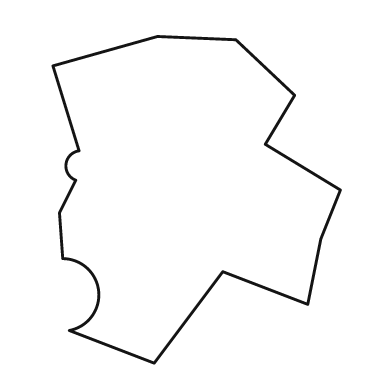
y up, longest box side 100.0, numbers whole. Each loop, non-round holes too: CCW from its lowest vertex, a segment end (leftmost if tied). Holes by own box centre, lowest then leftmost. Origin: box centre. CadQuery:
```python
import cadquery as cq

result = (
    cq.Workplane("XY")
    .moveTo(-13.0, -50.0)
    .lineTo(8.0, -22.0)
    .lineTo(34.0, -32.0)
    .lineTo(38.0, -12.0)
    .lineTo(44.0, 3.0)
    .lineTo(21.0, 17.0)
    .lineTo(30.0, 32.0)
    .lineTo(12.0, 49.0)
    .lineTo(-12.0, 50.0)
    .lineTo(-44.0, 41.0)
    .lineTo(-36.0, 15.0)
    .threePointArc((-40.0, 11.0), (-37.0, 6.0))
    .lineTo(-42.0, -4.0)
    .lineTo(-41.0, -18.0)
    .threePointArc((-30.0, -28.0), (-39.0, -40.0))
    .close()
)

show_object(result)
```